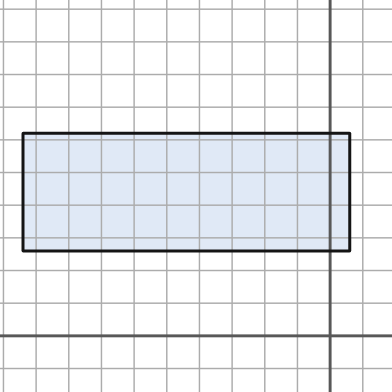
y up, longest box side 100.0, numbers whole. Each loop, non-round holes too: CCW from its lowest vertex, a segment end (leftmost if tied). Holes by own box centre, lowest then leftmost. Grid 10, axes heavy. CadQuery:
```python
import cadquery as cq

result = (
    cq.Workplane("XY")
    .moveTo(-94.0, 26.0)
    .lineTo(6.0, 26.0)
    .lineTo(6.0, 62.0)
    .lineTo(-94.0, 62.0)
    .close()
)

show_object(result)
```